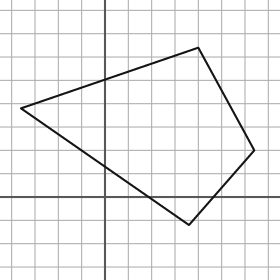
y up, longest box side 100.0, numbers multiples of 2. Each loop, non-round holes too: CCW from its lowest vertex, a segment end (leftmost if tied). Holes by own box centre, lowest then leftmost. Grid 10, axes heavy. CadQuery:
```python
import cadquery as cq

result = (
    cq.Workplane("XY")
    .moveTo(36.0, -12.0)
    .lineTo(64.0, 20.0)
    .lineTo(40.0, 64.0)
    .lineTo(-36.0, 38.0)
    .close()
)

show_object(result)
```